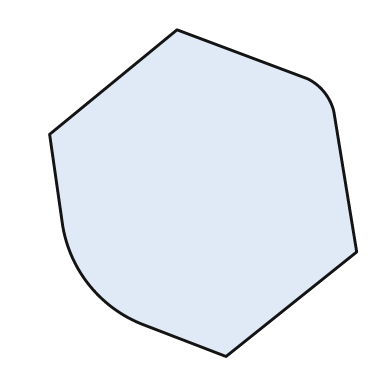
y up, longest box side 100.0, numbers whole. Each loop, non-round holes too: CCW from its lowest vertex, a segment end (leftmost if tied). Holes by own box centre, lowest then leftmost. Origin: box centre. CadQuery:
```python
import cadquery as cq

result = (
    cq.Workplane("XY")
    .moveTo(7.0, -50.0)
    .lineTo(47.0, -18.0)
    .lineTo(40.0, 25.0)
    .threePointArc((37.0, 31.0), (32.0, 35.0))
    .lineTo(-8.0, 50.0)
    .lineTo(-47.0, 18.0)
    .lineTo(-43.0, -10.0)
    .threePointArc((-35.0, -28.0), (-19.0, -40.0))
    .close()
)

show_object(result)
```